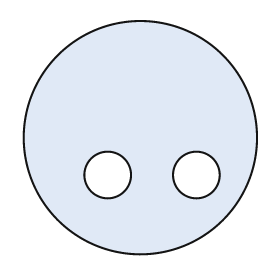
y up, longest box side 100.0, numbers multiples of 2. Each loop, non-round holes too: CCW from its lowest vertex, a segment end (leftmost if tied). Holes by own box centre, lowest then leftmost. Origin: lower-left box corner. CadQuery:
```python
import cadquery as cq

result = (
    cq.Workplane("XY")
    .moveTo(50.0, 50.0)
    .circle(50.0)
    .moveTo(36.0, 34.0)
    .circle(10.0)
    .moveTo(74.0, 34.0)
    .circle(10.0)
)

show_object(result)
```